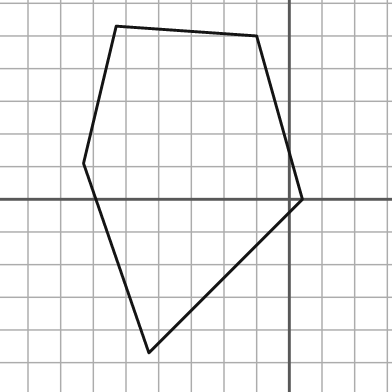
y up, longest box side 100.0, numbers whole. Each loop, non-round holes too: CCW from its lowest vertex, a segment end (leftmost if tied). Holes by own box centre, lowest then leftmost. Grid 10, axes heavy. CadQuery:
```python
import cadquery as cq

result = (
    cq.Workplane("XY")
    .moveTo(-43.0, -47.0)
    .lineTo(4.0, 0.0)
    .lineTo(-10.0, 50.0)
    .lineTo(-53.0, 53.0)
    .lineTo(-63.0, 11.0)
    .close()
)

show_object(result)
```